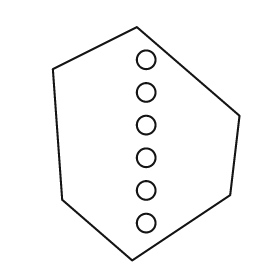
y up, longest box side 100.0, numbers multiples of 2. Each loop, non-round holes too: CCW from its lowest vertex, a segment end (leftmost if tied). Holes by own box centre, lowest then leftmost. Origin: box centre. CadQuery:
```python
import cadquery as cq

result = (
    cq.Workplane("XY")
    .moveTo(-6.0, -50.0)
    .lineTo(36.0, -22.0)
    .lineTo(40.0, 12.0)
    .lineTo(-4.0, 50.0)
    .lineTo(-40.0, 32.0)
    .lineTo(-36.0, -24.0)
    .close()
    .moveTo(0.0, -34.0)
    .circle(4.0)
    .moveTo(0.0, -20.0)
    .circle(4.0)
    .moveTo(0.0, -6.0)
    .circle(4.0)
    .moveTo(0.0, 8.0)
    .circle(4.0)
    .moveTo(0.0, 22.0)
    .circle(4.0)
    .moveTo(0.0, 36.0)
    .circle(4.0)
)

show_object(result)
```